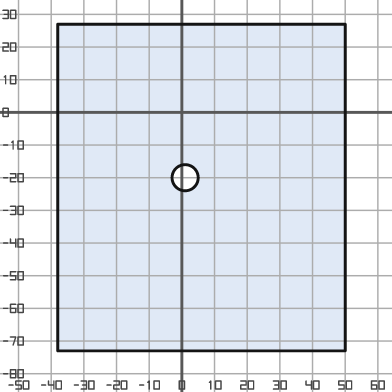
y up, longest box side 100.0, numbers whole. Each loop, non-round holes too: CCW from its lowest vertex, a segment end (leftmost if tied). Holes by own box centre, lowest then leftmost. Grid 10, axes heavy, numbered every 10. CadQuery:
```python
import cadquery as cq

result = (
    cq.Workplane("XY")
    .moveTo(-38.0, -73.0)
    .lineTo(50.0, -73.0)
    .lineTo(50.0, 27.0)
    .lineTo(-38.0, 27.0)
    .close()
    .moveTo(1.0, -20.0)
    .circle(4.0)
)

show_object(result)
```